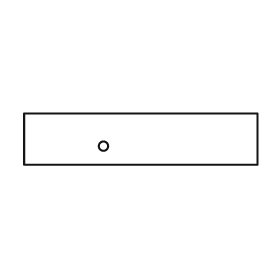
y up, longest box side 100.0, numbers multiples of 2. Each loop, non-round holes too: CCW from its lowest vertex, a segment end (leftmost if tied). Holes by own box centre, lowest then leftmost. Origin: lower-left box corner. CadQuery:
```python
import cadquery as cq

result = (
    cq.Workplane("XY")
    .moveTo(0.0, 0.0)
    .lineTo(100.0, 0.0)
    .lineTo(100.0, 22.0)
    .lineTo(0.0, 22.0)
    .close()
    .moveTo(34.0, 8.0)
    .circle(2.0)
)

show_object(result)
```